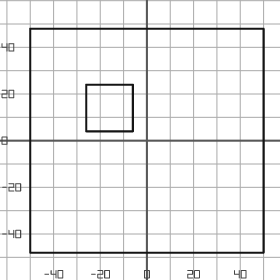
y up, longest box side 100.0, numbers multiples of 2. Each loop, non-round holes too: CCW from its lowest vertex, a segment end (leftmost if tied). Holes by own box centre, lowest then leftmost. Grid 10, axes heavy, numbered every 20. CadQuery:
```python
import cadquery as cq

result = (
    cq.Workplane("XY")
    .moveTo(-50.0, -48.0)
    .lineTo(50.0, -48.0)
    .lineTo(50.0, 48.0)
    .lineTo(-50.0, 48.0)
    .close()
    .moveTo(-26.0, 4.0)
    .lineTo(-6.0, 4.0)
    .lineTo(-6.0, 24.0)
    .lineTo(-26.0, 24.0)
    .close()
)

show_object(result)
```